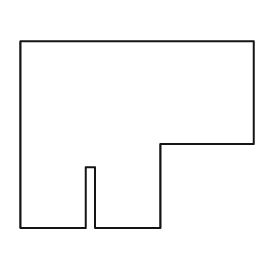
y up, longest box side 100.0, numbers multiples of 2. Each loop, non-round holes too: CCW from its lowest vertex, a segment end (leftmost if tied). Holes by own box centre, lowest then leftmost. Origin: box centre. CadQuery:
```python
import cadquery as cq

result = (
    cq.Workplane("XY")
    .moveTo(-50.0, -40.0)
    .lineTo(-22.0, -40.0)
    .lineTo(-22.0, -14.0)
    .lineTo(-18.0, -14.0)
    .lineTo(-18.0, -40.0)
    .lineTo(10.0, -40.0)
    .lineTo(10.0, -4.0)
    .lineTo(50.0, -4.0)
    .lineTo(50.0, 40.0)
    .lineTo(-50.0, 40.0)
    .close()
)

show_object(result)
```